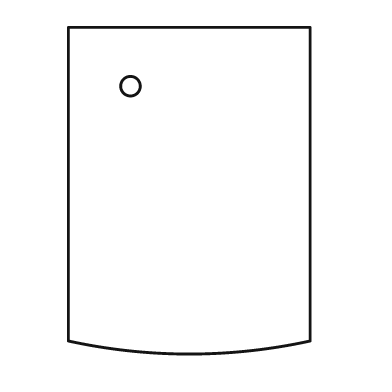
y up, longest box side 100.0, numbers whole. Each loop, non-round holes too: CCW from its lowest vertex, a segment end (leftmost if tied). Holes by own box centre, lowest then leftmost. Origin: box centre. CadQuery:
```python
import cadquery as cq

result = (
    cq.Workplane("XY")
    .moveTo(-37.0, -46.0)
    .threePointArc((0.0, -50.0), (37.0, -46.0))
    .lineTo(37.0, 50.0)
    .lineTo(-37.0, 50.0)
    .close()
    .moveTo(-18.0, 32.0)
    .circle(3.0)
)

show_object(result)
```